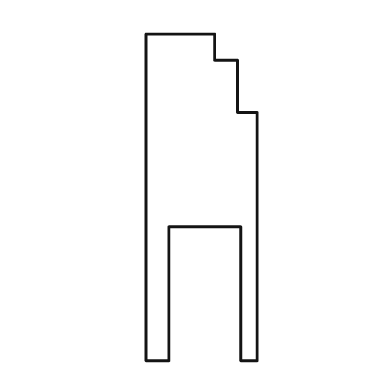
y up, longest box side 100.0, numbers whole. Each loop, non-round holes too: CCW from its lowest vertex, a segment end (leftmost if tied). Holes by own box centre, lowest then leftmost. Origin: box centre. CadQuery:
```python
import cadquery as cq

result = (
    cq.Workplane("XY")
    .moveTo(-17.0, -50.0)
    .lineTo(-10.0, -50.0)
    .lineTo(-10.0, -9.0)
    .lineTo(12.0, -9.0)
    .lineTo(12.0, -50.0)
    .lineTo(17.0, -50.0)
    .lineTo(17.0, 26.0)
    .lineTo(11.0, 26.0)
    .lineTo(11.0, 42.0)
    .lineTo(4.0, 42.0)
    .lineTo(4.0, 50.0)
    .lineTo(-17.0, 50.0)
    .close()
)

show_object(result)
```